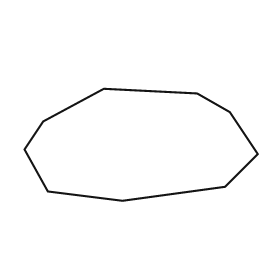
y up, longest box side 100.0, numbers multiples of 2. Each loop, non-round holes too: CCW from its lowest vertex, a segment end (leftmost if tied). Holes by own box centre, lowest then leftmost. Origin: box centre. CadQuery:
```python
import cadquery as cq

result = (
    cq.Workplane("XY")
    .moveTo(-8.0, -24.0)
    .lineTo(36.0, -18.0)
    .lineTo(50.0, -4.0)
    .lineTo(38.0, 14.0)
    .lineTo(24.0, 22.0)
    .lineTo(-16.0, 24.0)
    .lineTo(-42.0, 10.0)
    .lineTo(-50.0, -2.0)
    .lineTo(-40.0, -20.0)
    .close()
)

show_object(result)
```